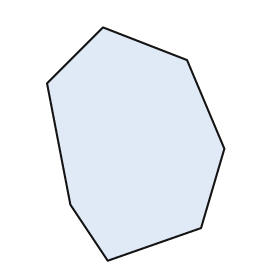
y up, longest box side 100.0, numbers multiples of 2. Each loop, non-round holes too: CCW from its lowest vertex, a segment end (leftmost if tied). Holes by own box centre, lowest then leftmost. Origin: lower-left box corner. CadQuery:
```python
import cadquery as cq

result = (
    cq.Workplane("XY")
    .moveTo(26.0, 0.0)
    .lineTo(66.0, 14.0)
    .lineTo(76.0, 48.0)
    .lineTo(60.0, 86.0)
    .lineTo(24.0, 100.0)
    .lineTo(0.0, 76.0)
    .lineTo(10.0, 24.0)
    .close()
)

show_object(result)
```